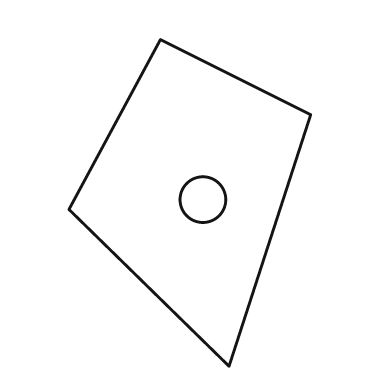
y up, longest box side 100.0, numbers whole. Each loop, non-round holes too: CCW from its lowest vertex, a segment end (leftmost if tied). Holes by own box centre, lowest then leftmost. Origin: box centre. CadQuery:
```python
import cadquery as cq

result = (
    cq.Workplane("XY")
    .moveTo(12.0, -50.0)
    .lineTo(37.0, 27.0)
    .lineTo(-9.0, 50.0)
    .lineTo(-37.0, -2.0)
    .close()
    .moveTo(4.0, 1.0)
    .circle(7.0)
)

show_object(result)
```